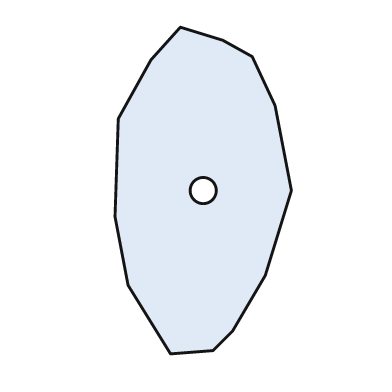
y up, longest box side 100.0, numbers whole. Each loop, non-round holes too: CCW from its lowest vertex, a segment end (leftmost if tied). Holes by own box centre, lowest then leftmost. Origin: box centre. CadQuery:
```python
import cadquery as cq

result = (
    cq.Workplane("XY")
    .moveTo(-10.0, -50.0)
    .lineTo(3.0, -49.0)
    .lineTo(9.0, -43.0)
    .lineTo(19.0, -26.0)
    .lineTo(27.0, 0.0)
    .lineTo(22.0, 26.0)
    .lineTo(15.0, 41.0)
    .lineTo(6.0, 46.0)
    .lineTo(-7.0, 50.0)
    .lineTo(-16.0, 40.0)
    .lineTo(-26.0, 22.0)
    .lineTo(-27.0, -8.0)
    .lineTo(-23.0, -29.0)
    .close()
    .moveTo(0.0, 0.0)
    .circle(4.0)
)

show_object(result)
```